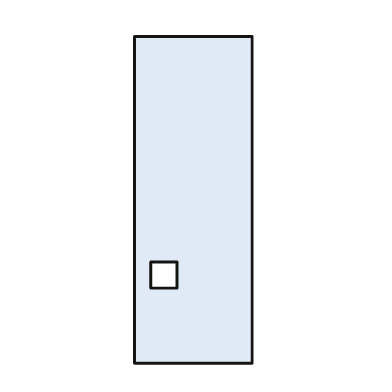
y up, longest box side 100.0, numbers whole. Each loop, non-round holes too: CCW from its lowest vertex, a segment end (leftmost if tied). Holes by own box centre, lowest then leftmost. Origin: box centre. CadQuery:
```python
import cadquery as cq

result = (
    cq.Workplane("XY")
    .moveTo(-18.0, -50.0)
    .lineTo(18.0, -50.0)
    .lineTo(18.0, 50.0)
    .lineTo(-18.0, 50.0)
    .close()
    .moveTo(-13.0, -27.0)
    .lineTo(-5.0, -27.0)
    .lineTo(-5.0, -19.0)
    .lineTo(-13.0, -19.0)
    .close()
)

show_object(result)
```